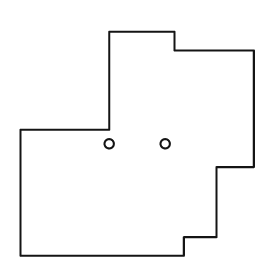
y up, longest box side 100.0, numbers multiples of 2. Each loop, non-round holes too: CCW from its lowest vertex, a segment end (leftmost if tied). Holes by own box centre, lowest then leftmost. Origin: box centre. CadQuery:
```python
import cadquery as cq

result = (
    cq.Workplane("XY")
    .moveTo(-50.0, -48.0)
    .lineTo(20.0, -48.0)
    .lineTo(20.0, -40.0)
    .lineTo(34.0, -40.0)
    .lineTo(34.0, -10.0)
    .lineTo(50.0, -10.0)
    .lineTo(50.0, 40.0)
    .lineTo(16.0, 40.0)
    .lineTo(16.0, 48.0)
    .lineTo(-12.0, 48.0)
    .lineTo(-12.0, 6.0)
    .lineTo(-50.0, 6.0)
    .close()
    .moveTo(-12.0, 0.0)
    .circle(2.0)
    .moveTo(12.0, 0.0)
    .circle(2.0)
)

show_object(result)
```